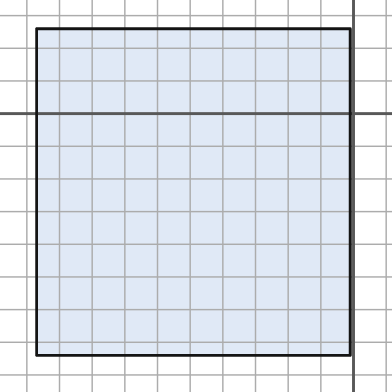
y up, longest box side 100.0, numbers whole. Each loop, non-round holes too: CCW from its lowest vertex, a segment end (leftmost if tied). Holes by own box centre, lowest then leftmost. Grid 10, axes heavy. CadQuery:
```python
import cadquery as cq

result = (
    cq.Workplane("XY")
    .moveTo(-97.0, -74.0)
    .lineTo(-1.0, -74.0)
    .lineTo(-1.0, 26.0)
    .lineTo(-97.0, 26.0)
    .close()
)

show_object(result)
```